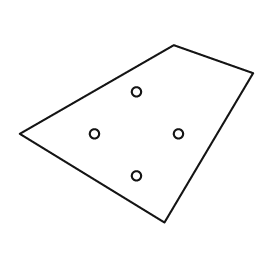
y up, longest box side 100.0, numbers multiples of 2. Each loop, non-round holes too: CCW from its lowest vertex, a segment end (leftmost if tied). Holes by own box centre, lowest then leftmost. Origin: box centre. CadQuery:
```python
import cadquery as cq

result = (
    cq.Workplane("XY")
    .moveTo(12.0, -38.0)
    .lineTo(50.0, 26.0)
    .lineTo(16.0, 38.0)
    .lineTo(-50.0, 0.0)
    .close()
    .moveTo(0.0, -18.0)
    .circle(2.0)
    .moveTo(-18.0, 0.0)
    .circle(2.0)
    .moveTo(18.0, 0.0)
    .circle(2.0)
    .moveTo(0.0, 18.0)
    .circle(2.0)
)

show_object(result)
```